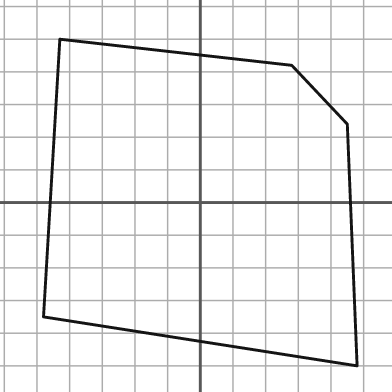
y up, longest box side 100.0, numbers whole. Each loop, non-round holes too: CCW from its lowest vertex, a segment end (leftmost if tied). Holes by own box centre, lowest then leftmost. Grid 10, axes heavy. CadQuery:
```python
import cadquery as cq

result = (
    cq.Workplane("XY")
    .moveTo(48.0, -50.0)
    .lineTo(45.0, 24.0)
    .lineTo(28.0, 42.0)
    .lineTo(-43.0, 50.0)
    .lineTo(-48.0, -35.0)
    .close()
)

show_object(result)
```